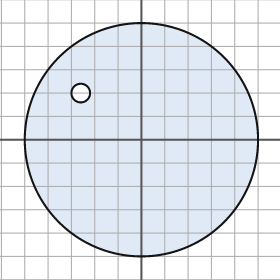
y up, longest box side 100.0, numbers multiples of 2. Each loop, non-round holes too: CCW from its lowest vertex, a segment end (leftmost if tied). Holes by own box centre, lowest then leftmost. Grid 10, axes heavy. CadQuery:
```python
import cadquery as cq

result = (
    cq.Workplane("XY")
    .moveTo(0.0, 0.0)
    .circle(50.0)
    .moveTo(-26.0, 20.0)
    .circle(4.0)
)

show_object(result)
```